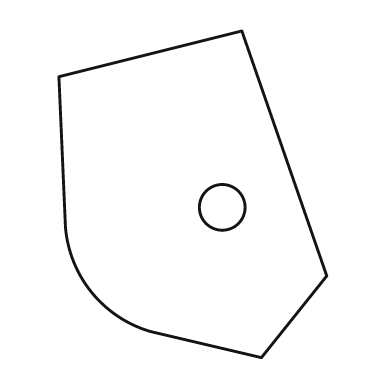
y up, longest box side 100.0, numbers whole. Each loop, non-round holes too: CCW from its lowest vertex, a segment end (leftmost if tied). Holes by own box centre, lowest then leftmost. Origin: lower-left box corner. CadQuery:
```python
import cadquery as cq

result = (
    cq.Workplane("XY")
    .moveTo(62.0, 0.0)
    .lineTo(82.0, 25.0)
    .lineTo(56.0, 100.0)
    .lineTo(0.0, 86.0)
    .lineTo(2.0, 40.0)
    .threePointArc((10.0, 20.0), (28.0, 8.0))
    .close()
    .moveTo(50.0, 46.0)
    .circle(7.0)
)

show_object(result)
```